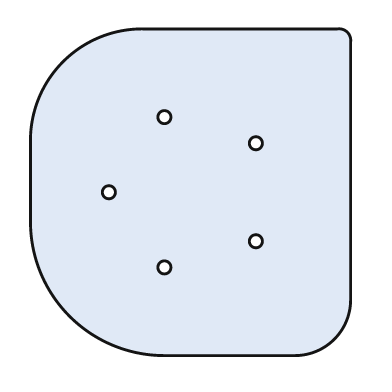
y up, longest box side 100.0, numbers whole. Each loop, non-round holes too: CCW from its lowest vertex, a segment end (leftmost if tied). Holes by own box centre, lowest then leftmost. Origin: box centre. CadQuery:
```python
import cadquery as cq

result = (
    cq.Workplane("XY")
    .moveTo(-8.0, -50.0)
    .lineTo(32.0, -50.0)
    .threePointArc((44.0, -45.0), (49.0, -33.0))
    .lineTo(49.0, 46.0)
    .threePointArc((48.0, 49.0), (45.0, 50.0))
    .lineTo(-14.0, 50.0)
    .threePointArc((-39.0, 40.0), (-49.0, 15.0))
    .lineTo(-49.0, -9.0)
    .threePointArc((-37.0, -38.0), (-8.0, -50.0))
    .close()
    .moveTo(-8.0, -23.0)
    .circle(2.0)
    .moveTo(20.0, -15.0)
    .circle(2.0)
    .moveTo(-25.0, 0.0)
    .circle(2.0)
    .moveTo(20.0, 15.0)
    .circle(2.0)
    .moveTo(-8.0, 23.0)
    .circle(2.0)
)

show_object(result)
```